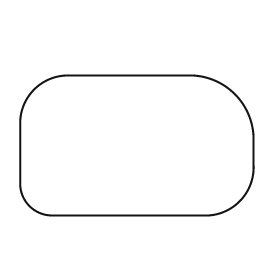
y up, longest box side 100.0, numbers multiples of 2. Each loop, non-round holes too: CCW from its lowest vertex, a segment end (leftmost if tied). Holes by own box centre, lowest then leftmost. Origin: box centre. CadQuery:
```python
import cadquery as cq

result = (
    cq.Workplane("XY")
    .moveTo(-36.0, -30.0)
    .lineTo(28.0, -30.0)
    .threePointArc((44.0, -24.0), (50.0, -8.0))
    .lineTo(50.0, 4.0)
    .threePointArc((42.0, 22.0), (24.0, 30.0))
    .lineTo(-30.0, 30.0)
    .threePointArc((-44.0, 24.0), (-50.0, 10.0))
    .lineTo(-50.0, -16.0)
    .threePointArc((-46.0, -26.0), (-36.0, -30.0))
    .close()
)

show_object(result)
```